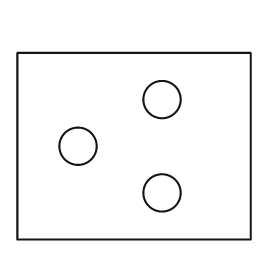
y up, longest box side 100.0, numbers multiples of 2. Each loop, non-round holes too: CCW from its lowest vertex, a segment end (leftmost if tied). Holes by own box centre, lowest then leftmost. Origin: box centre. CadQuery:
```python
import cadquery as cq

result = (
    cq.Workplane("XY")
    .moveTo(-50.0, -40.0)
    .lineTo(50.0, -40.0)
    .lineTo(50.0, 40.0)
    .lineTo(-50.0, 40.0)
    .close()
    .moveTo(12.0, -20.0)
    .circle(8.0)
    .moveTo(-24.0, 0.0)
    .circle(8.0)
    .moveTo(12.0, 20.0)
    .circle(8.0)
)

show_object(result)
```